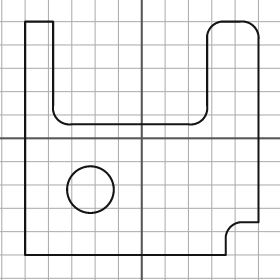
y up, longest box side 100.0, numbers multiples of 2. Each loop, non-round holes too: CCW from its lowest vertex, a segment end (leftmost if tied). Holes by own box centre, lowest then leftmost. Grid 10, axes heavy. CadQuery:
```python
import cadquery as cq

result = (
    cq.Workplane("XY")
    .moveTo(-50.0, -50.0)
    .lineTo(36.0, -50.0)
    .lineTo(36.0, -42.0)
    .threePointArc((38.0, -38.0), (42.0, -36.0))
    .lineTo(50.0, -36.0)
    .lineTo(50.0, 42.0)
    .threePointArc((48.0, 48.0), (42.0, 50.0))
    .lineTo(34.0, 50.0)
    .threePointArc((30.0, 48.0), (28.0, 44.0))
    .lineTo(28.0, 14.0)
    .threePointArc((26.0, 8.0), (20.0, 6.0))
    .lineTo(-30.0, 6.0)
    .threePointArc((-36.0, 8.0), (-38.0, 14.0))
    .lineTo(-38.0, 50.0)
    .lineTo(-50.0, 50.0)
    .close()
    .moveTo(-22.0, -22.0)
    .circle(10.0)
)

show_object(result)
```